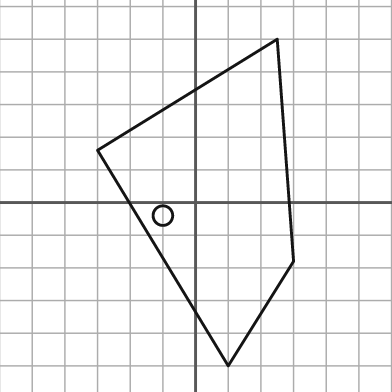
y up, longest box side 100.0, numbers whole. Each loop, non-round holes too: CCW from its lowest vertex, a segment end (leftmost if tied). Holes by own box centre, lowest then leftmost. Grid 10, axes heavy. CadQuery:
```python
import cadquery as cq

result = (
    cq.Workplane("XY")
    .moveTo(10.0, -50.0)
    .lineTo(30.0, -18.0)
    .lineTo(25.0, 50.0)
    .lineTo(-30.0, 16.0)
    .close()
    .moveTo(-10.0, -4.0)
    .circle(3.0)
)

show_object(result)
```